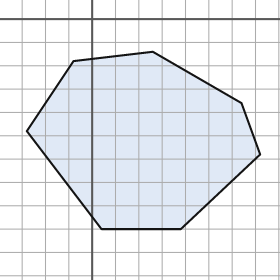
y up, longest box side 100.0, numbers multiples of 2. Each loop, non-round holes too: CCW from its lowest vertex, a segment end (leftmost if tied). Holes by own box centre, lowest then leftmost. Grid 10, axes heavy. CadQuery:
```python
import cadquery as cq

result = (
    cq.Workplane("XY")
    .moveTo(4.0, -90.0)
    .lineTo(38.0, -90.0)
    .lineTo(72.0, -58.0)
    .lineTo(64.0, -36.0)
    .lineTo(26.0, -14.0)
    .lineTo(-8.0, -18.0)
    .lineTo(-28.0, -48.0)
    .close()
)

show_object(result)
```